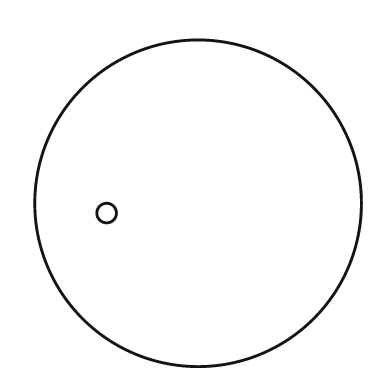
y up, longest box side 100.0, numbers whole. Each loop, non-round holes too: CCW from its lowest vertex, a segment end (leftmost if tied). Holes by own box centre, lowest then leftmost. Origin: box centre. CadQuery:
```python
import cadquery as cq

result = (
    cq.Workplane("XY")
    .moveTo(0.0, 0.0)
    .circle(50.0)
    .moveTo(-28.0, -3.0)
    .circle(3.0)
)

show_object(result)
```